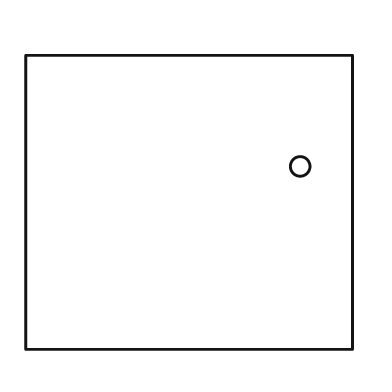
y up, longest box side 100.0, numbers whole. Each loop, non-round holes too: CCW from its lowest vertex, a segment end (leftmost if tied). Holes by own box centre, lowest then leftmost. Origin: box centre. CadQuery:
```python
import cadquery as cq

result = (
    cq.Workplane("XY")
    .moveTo(-50.0, -45.0)
    .lineTo(50.0, -45.0)
    .lineTo(50.0, 45.0)
    .lineTo(-50.0, 45.0)
    .close()
    .moveTo(34.0, 11.0)
    .circle(3.0)
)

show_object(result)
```